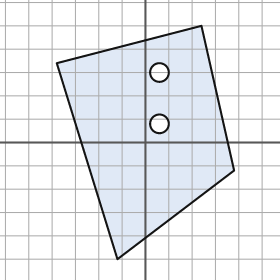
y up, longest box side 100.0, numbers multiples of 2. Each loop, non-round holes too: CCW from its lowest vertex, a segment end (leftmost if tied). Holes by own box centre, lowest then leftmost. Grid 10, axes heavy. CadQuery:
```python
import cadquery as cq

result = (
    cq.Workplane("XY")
    .moveTo(-12.0, -50.0)
    .lineTo(38.0, -12.0)
    .lineTo(24.0, 50.0)
    .lineTo(-38.0, 34.0)
    .close()
    .moveTo(6.0, 8.0)
    .circle(4.0)
    .moveTo(6.0, 30.0)
    .circle(4.0)
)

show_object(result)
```